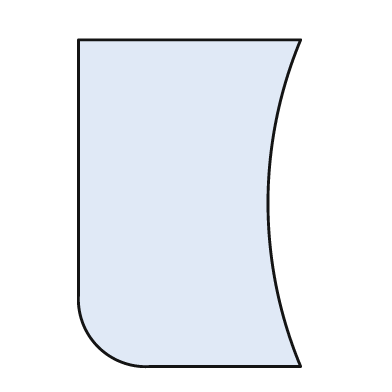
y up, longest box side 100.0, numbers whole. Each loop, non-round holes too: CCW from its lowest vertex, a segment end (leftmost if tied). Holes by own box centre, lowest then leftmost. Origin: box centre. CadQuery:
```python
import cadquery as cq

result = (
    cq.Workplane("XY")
    .moveTo(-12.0, -50.0)
    .lineTo(34.0, -50.0)
    .threePointArc((24.0, 0.0), (34.0, 50.0))
    .lineTo(-34.0, 50.0)
    .lineTo(-34.0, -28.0)
    .threePointArc((-28.0, -44.0), (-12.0, -50.0))
    .close()
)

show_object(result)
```